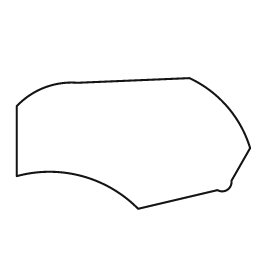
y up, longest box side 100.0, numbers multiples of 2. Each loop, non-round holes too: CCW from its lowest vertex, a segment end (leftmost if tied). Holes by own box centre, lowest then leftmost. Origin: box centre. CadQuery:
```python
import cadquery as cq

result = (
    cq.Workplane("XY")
    .moveTo(2.0, -28.0)
    .lineTo(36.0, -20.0)
    .threePointArc((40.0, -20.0), (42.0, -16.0))
    .lineTo(50.0, -2.0)
    .threePointArc((40.0, 16.0), (24.0, 28.0))
    .lineTo(-24.0, 26.0)
    .threePointArc((-38.0, 24.0), (-50.0, 16.0))
    .lineTo(-50.0, -14.0)
    .threePointArc((-22.0, -14.0), (2.0, -28.0))
    .close()
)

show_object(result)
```